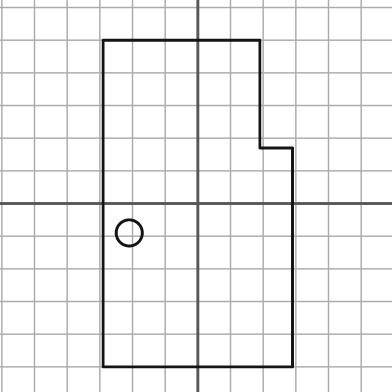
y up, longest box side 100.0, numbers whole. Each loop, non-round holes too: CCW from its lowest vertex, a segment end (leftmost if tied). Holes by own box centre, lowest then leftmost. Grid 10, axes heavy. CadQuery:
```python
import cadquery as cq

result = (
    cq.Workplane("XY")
    .moveTo(-29.0, -50.0)
    .lineTo(29.0, -50.0)
    .lineTo(29.0, 17.0)
    .lineTo(19.0, 17.0)
    .lineTo(19.0, 50.0)
    .lineTo(-29.0, 50.0)
    .close()
    .moveTo(-21.0, -9.0)
    .circle(4.0)
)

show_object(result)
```